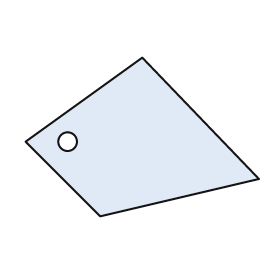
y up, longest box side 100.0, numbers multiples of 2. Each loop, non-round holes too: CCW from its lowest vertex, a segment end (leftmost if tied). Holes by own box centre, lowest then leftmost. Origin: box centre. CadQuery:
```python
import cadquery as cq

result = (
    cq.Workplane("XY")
    .moveTo(-18.0, -34.0)
    .lineTo(50.0, -18.0)
    .lineTo(0.0, 34.0)
    .lineTo(-50.0, -2.0)
    .close()
    .moveTo(-32.0, -2.0)
    .circle(4.0)
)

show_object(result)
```